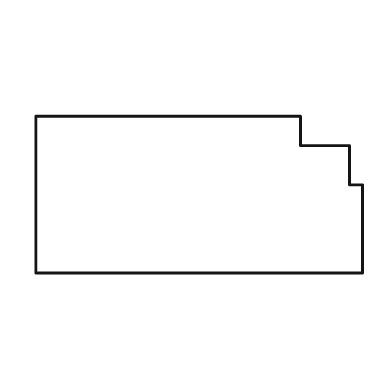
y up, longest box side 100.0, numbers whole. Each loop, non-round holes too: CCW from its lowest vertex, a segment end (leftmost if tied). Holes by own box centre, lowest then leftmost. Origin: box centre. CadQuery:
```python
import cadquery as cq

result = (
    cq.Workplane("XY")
    .moveTo(-50.0, -24.0)
    .lineTo(50.0, -24.0)
    .lineTo(50.0, 3.0)
    .lineTo(46.0, 3.0)
    .lineTo(46.0, 15.0)
    .lineTo(31.0, 15.0)
    .lineTo(31.0, 24.0)
    .lineTo(-50.0, 24.0)
    .close()
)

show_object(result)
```